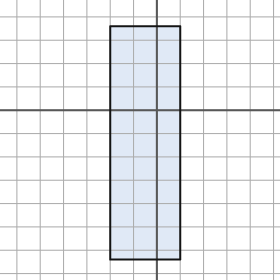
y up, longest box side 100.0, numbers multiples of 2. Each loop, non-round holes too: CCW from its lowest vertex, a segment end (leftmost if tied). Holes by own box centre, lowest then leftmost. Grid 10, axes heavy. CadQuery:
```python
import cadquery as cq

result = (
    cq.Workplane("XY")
    .moveTo(-20.0, -64.0)
    .lineTo(10.0, -64.0)
    .lineTo(10.0, 36.0)
    .lineTo(-20.0, 36.0)
    .close()
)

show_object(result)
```